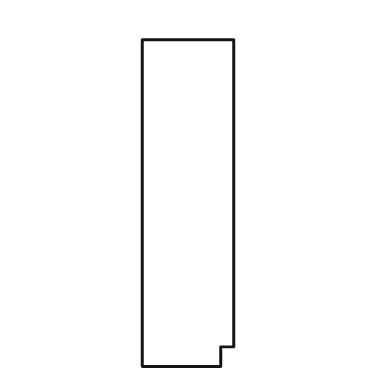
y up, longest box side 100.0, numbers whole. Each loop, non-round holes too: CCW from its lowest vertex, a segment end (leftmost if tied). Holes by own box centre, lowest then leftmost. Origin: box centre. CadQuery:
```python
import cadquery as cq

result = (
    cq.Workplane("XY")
    .moveTo(-14.0, -50.0)
    .lineTo(10.0, -50.0)
    .lineTo(10.0, -44.0)
    .lineTo(14.0, -44.0)
    .lineTo(14.0, 50.0)
    .lineTo(-14.0, 50.0)
    .close()
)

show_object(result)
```